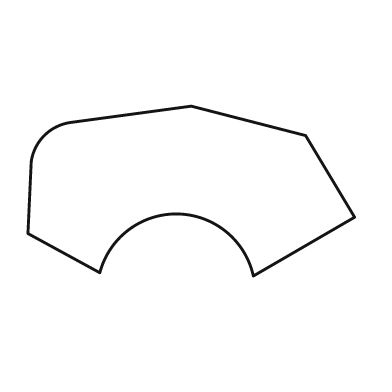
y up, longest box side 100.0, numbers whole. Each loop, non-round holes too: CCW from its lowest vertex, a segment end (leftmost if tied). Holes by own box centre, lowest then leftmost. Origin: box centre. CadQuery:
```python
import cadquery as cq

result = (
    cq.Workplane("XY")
    .moveTo(19.0, -26.0)
    .lineTo(50.0, -8.0)
    .lineTo(35.0, 17.0)
    .lineTo(0.0, 26.0)
    .lineTo(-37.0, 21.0)
    .threePointArc((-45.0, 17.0), (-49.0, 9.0))
    .lineTo(-50.0, -13.0)
    .lineTo(-28.0, -25.0)
    .threePointArc((-4.0, -7.0), (19.0, -26.0))
    .close()
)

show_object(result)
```